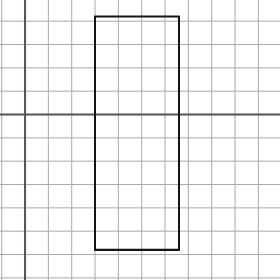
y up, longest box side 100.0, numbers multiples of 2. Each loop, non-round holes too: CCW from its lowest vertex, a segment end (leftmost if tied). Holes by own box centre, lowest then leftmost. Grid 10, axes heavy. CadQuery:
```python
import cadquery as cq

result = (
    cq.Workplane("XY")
    .moveTo(30.0, -58.0)
    .lineTo(66.0, -58.0)
    .lineTo(66.0, 42.0)
    .lineTo(30.0, 42.0)
    .close()
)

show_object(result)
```